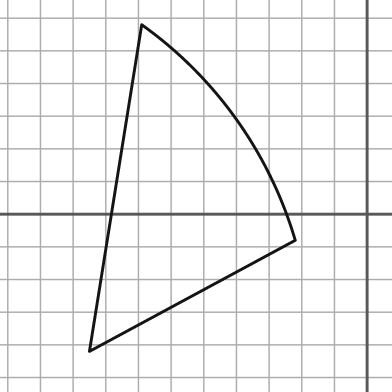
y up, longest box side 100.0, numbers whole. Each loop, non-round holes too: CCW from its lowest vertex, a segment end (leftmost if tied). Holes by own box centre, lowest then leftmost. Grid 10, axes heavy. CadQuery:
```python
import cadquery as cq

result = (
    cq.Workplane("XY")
    .moveTo(-85.0, -42.0)
    .lineTo(-22.0, -8.0)
    .threePointArc((-40.0, 29.0), (-69.0, 58.0))
    .close()
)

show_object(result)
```